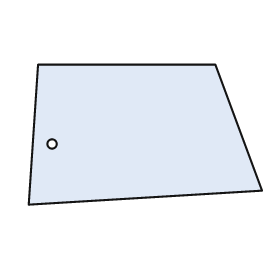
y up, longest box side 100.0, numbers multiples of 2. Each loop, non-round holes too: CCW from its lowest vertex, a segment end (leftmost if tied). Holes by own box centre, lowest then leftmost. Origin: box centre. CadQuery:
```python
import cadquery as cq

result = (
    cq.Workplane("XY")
    .moveTo(-50.0, -30.0)
    .lineTo(50.0, -24.0)
    .lineTo(30.0, 30.0)
    .lineTo(-46.0, 30.0)
    .close()
    .moveTo(-40.0, -4.0)
    .circle(2.0)
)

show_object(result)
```